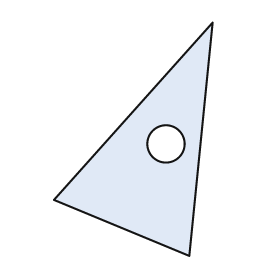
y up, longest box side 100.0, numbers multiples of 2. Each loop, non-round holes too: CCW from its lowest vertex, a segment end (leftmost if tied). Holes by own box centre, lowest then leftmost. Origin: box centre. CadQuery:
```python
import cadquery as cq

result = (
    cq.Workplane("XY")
    .moveTo(24.0, -50.0)
    .lineTo(34.0, 50.0)
    .lineTo(-34.0, -26.0)
    .close()
    .moveTo(14.0, -2.0)
    .circle(8.0)
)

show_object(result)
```